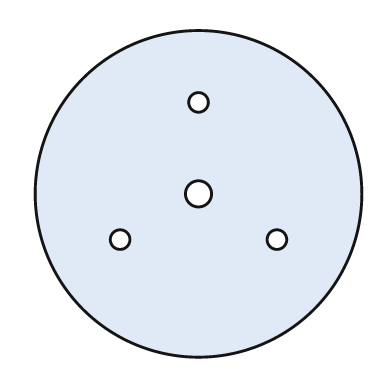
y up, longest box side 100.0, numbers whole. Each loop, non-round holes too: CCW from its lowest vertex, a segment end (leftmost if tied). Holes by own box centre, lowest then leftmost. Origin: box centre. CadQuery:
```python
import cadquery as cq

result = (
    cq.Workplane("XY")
    .moveTo(0.0, 0.0)
    .circle(50.0)
    .moveTo(-24.0, -14.0)
    .circle(3.0)
    .moveTo(24.0, -14.0)
    .circle(3.0)
    .moveTo(0.0, 0.0)
    .circle(4.0)
    .moveTo(0.0, 28.0)
    .circle(3.0)
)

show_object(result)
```